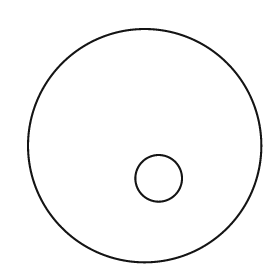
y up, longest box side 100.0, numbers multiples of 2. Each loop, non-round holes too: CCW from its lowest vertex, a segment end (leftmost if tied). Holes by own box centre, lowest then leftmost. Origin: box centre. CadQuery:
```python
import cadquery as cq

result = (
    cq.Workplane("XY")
    .moveTo(0.0, 0.0)
    .circle(50.0)
    .moveTo(6.0, -14.0)
    .circle(10.0)
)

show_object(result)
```